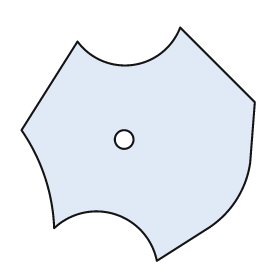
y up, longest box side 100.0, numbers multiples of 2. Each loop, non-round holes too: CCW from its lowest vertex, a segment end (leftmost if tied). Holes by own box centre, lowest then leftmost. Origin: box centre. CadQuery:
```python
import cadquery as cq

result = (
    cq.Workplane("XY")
    .moveTo(8.0, -50.0)
    .lineTo(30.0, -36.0)
    .threePointArc((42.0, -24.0), (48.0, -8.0))
    .lineTo(50.0, 18.0)
    .lineTo(18.0, 50.0)
    .threePointArc((-2.0, 34.0), (-26.0, 44.0))
    .lineTo(-50.0, 6.0)
    .threePointArc((-40.0, -14.0), (-36.0, -36.0))
    .threePointArc((-10.0, -30.0), (8.0, -50.0))
    .close()
    .moveTo(-6.0, 2.0)
    .circle(4.0)
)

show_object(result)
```